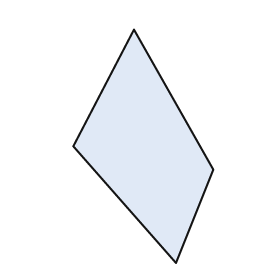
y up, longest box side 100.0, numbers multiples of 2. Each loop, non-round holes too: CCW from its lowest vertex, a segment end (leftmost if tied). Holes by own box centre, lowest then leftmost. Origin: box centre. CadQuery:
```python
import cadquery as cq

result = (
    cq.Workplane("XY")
    .moveTo(14.0, -50.0)
    .lineTo(30.0, -10.0)
    .lineTo(-4.0, 50.0)
    .lineTo(-30.0, 0.0)
    .close()
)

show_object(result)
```